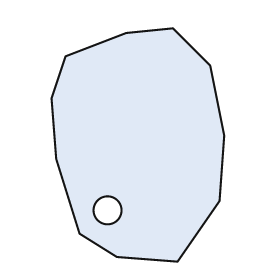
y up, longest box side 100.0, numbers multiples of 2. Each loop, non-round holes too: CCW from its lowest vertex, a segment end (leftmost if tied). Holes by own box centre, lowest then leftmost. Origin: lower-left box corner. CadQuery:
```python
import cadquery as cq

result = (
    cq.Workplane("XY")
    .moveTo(54.0, 0.0)
    .lineTo(72.0, 26.0)
    .lineTo(74.0, 54.0)
    .lineTo(68.0, 84.0)
    .lineTo(52.0, 100.0)
    .lineTo(32.0, 98.0)
    .lineTo(6.0, 88.0)
    .lineTo(0.0, 70.0)
    .lineTo(2.0, 44.0)
    .lineTo(12.0, 12.0)
    .lineTo(28.0, 2.0)
    .close()
    .moveTo(24.0, 22.0)
    .circle(6.0)
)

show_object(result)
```